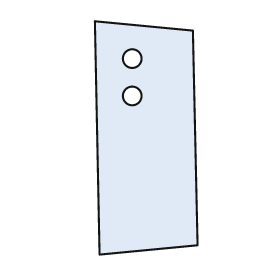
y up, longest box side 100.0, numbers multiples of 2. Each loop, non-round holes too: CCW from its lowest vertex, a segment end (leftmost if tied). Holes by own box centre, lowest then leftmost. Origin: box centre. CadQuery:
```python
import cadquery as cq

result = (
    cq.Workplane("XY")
    .moveTo(-20.0, -50.0)
    .lineTo(22.0, -46.0)
    .lineTo(20.0, 46.0)
    .lineTo(-22.0, 50.0)
    .close()
    .moveTo(-6.0, 18.0)
    .circle(4.0)
    .moveTo(-6.0, 34.0)
    .circle(4.0)
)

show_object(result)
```